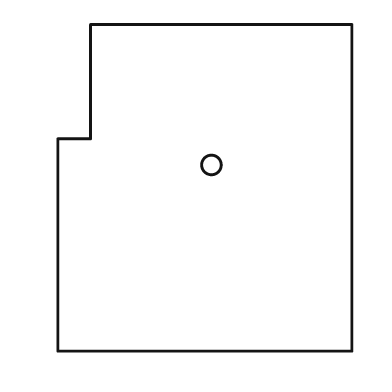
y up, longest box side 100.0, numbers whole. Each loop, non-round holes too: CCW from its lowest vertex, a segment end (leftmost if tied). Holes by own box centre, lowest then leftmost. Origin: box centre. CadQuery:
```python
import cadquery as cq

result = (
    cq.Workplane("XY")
    .moveTo(-45.0, -50.0)
    .lineTo(45.0, -50.0)
    .lineTo(45.0, 50.0)
    .lineTo(-35.0, 50.0)
    .lineTo(-35.0, 15.0)
    .lineTo(-45.0, 15.0)
    .close()
    .moveTo(2.0, 7.0)
    .circle(3.0)
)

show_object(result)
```